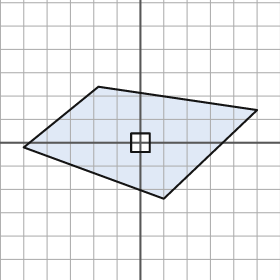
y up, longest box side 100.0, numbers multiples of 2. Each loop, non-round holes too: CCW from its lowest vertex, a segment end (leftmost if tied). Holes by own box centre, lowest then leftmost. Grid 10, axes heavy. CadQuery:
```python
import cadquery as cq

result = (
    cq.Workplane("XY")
    .moveTo(10.0, -24.0)
    .lineTo(50.0, 14.0)
    .lineTo(-18.0, 24.0)
    .lineTo(-50.0, -2.0)
    .close()
    .moveTo(-4.0, -4.0)
    .lineTo(4.0, -4.0)
    .lineTo(4.0, 4.0)
    .lineTo(-4.0, 4.0)
    .close()
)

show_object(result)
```